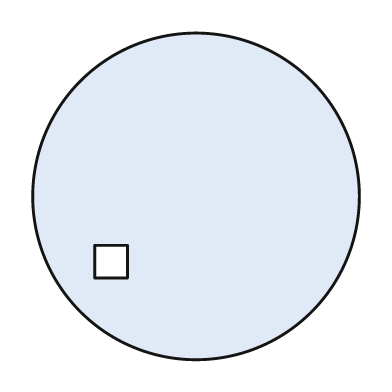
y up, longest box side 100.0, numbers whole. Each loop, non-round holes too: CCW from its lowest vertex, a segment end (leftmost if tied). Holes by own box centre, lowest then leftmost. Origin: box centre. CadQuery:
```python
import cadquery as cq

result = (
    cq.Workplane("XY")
    .moveTo(0.0, 0.0)
    .circle(50.0)
    .moveTo(-31.0, -25.0)
    .lineTo(-21.0, -25.0)
    .lineTo(-21.0, -15.0)
    .lineTo(-31.0, -15.0)
    .close()
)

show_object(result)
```